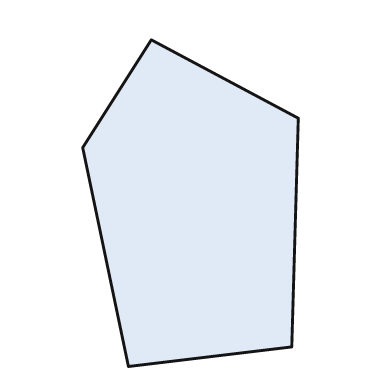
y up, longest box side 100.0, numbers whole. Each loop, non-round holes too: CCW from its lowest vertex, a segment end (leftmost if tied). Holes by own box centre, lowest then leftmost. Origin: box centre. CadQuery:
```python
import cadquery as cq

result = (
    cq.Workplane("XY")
    .moveTo(-19.0, -50.0)
    .lineTo(31.0, -44.0)
    .lineTo(33.0, 26.0)
    .lineTo(-12.0, 50.0)
    .lineTo(-33.0, 17.0)
    .close()
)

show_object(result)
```